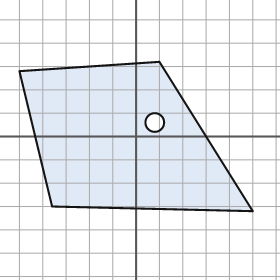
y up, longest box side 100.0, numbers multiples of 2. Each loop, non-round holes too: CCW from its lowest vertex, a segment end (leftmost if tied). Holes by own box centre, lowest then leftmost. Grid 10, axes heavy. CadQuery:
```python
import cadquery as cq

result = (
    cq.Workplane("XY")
    .moveTo(50.0, -32.0)
    .lineTo(10.0, 32.0)
    .lineTo(-50.0, 28.0)
    .lineTo(-36.0, -30.0)
    .close()
    .moveTo(8.0, 6.0)
    .circle(4.0)
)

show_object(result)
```